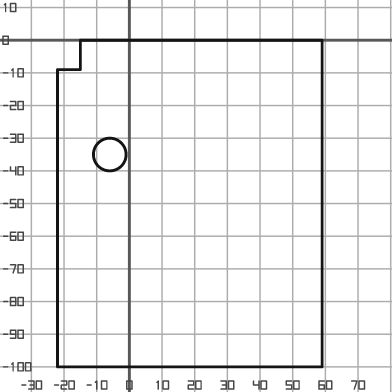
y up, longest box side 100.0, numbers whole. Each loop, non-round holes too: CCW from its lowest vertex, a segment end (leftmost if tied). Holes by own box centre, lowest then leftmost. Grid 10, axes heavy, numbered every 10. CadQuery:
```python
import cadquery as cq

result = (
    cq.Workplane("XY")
    .moveTo(-22.0, -100.0)
    .lineTo(59.0, -100.0)
    .lineTo(59.0, 0.0)
    .lineTo(-15.0, 0.0)
    .lineTo(-15.0, -9.0)
    .lineTo(-22.0, -9.0)
    .close()
    .moveTo(-6.0, -35.0)
    .circle(5.0)
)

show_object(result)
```